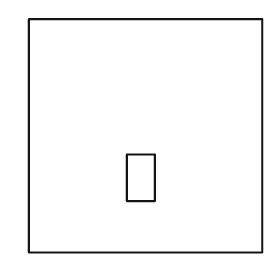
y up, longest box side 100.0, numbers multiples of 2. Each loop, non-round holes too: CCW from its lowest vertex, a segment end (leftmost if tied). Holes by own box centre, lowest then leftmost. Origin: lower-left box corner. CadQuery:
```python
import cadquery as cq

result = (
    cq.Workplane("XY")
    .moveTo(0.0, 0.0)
    .lineTo(100.0, 0.0)
    .lineTo(100.0, 100.0)
    .lineTo(0.0, 100.0)
    .close()
    .moveTo(42.0, 22.0)
    .lineTo(54.0, 22.0)
    .lineTo(54.0, 42.0)
    .lineTo(42.0, 42.0)
    .close()
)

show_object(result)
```